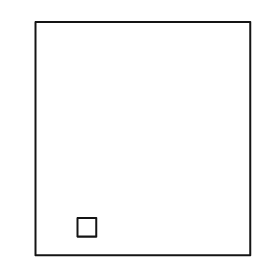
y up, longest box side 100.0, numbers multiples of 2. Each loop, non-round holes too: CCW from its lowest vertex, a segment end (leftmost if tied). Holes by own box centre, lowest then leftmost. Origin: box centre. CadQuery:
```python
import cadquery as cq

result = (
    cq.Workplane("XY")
    .moveTo(-46.0, -50.0)
    .lineTo(46.0, -50.0)
    .lineTo(46.0, 50.0)
    .lineTo(-46.0, 50.0)
    .close()
    .moveTo(-28.0, -42.0)
    .lineTo(-20.0, -42.0)
    .lineTo(-20.0, -34.0)
    .lineTo(-28.0, -34.0)
    .close()
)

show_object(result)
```